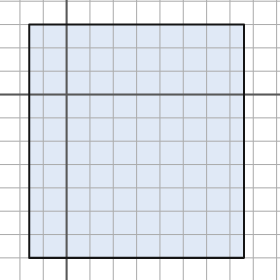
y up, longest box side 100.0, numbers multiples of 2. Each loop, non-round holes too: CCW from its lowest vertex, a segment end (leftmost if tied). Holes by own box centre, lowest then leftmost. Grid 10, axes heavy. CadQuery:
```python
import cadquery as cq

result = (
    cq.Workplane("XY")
    .moveTo(-16.0, -70.0)
    .lineTo(76.0, -70.0)
    .lineTo(76.0, 30.0)
    .lineTo(-16.0, 30.0)
    .close()
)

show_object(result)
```